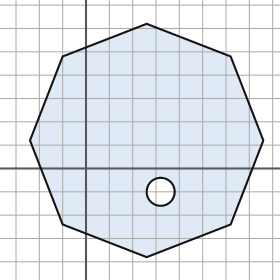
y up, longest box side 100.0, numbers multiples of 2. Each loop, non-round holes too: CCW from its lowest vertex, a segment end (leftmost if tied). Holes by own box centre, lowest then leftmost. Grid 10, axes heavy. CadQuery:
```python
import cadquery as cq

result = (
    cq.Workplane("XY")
    .moveTo(26.0, -38.0)
    .lineTo(62.0, -24.0)
    .lineTo(76.0, 12.0)
    .lineTo(62.0, 48.0)
    .lineTo(26.0, 62.0)
    .lineTo(-10.0, 48.0)
    .lineTo(-24.0, 12.0)
    .lineTo(-10.0, -24.0)
    .close()
    .moveTo(32.0, -10.0)
    .circle(6.0)
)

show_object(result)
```